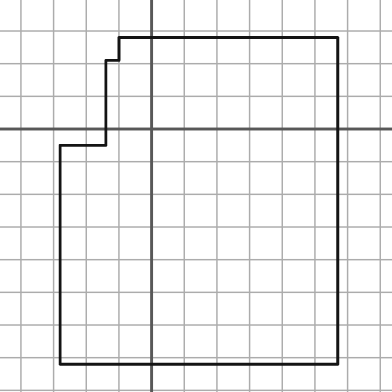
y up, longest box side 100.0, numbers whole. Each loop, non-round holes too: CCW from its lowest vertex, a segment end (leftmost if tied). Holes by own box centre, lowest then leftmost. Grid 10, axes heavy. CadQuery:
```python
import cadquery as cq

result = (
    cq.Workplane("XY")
    .moveTo(-28.0, -72.0)
    .lineTo(57.0, -72.0)
    .lineTo(57.0, 28.0)
    .lineTo(-10.0, 28.0)
    .lineTo(-10.0, 21.0)
    .lineTo(-14.0, 21.0)
    .lineTo(-14.0, -5.0)
    .lineTo(-28.0, -5.0)
    .close()
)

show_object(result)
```